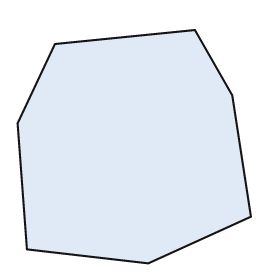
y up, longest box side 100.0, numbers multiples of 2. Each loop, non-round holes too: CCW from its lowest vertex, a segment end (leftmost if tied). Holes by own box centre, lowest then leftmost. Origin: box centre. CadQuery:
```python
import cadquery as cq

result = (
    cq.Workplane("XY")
    .moveTo(6.0, -50.0)
    .lineTo(50.0, -30.0)
    .lineTo(42.0, 22.0)
    .lineTo(26.0, 50.0)
    .lineTo(-34.0, 44.0)
    .lineTo(-50.0, 10.0)
    .lineTo(-46.0, -44.0)
    .close()
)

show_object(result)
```